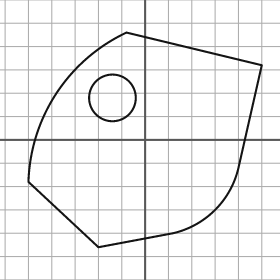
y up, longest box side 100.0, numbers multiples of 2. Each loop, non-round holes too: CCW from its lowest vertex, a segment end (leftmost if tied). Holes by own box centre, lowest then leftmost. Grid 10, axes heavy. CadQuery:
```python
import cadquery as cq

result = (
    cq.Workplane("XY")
    .moveTo(-20.0, -46.0)
    .lineTo(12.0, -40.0)
    .threePointArc((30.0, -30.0), (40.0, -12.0))
    .lineTo(50.0, 32.0)
    .lineTo(-8.0, 46.0)
    .threePointArc((-38.0, 20.0), (-50.0, -18.0))
    .close()
    .moveTo(-14.0, 18.0)
    .circle(10.0)
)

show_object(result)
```